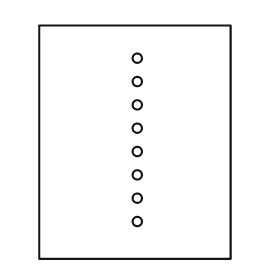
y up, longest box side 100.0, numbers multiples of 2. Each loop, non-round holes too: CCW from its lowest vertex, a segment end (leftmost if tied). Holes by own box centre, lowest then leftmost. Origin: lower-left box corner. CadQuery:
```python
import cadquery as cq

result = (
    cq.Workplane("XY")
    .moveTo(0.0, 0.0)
    .lineTo(82.0, 0.0)
    .lineTo(82.0, 100.0)
    .lineTo(0.0, 100.0)
    .close()
    .moveTo(42.0, 16.0)
    .circle(2.0)
    .moveTo(42.0, 26.0)
    .circle(2.0)
    .moveTo(42.0, 36.0)
    .circle(2.0)
    .moveTo(42.0, 46.0)
    .circle(2.0)
    .moveTo(42.0, 56.0)
    .circle(2.0)
    .moveTo(42.0, 66.0)
    .circle(2.0)
    .moveTo(42.0, 76.0)
    .circle(2.0)
    .moveTo(42.0, 86.0)
    .circle(2.0)
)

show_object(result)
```